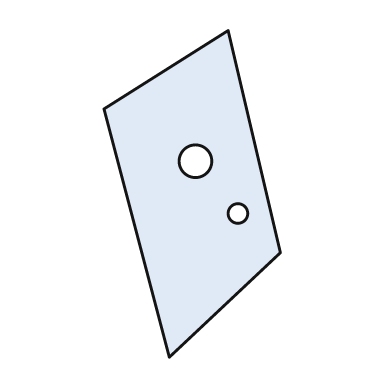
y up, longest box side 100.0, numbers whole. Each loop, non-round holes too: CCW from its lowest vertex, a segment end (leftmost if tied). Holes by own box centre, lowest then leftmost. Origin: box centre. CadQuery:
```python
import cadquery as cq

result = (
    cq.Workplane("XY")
    .moveTo(-7.0, -50.0)
    .lineTo(27.0, -18.0)
    .lineTo(11.0, 50.0)
    .lineTo(-27.0, 26.0)
    .close()
    .moveTo(14.0, -6.0)
    .circle(3.0)
    .moveTo(1.0, 10.0)
    .circle(5.0)
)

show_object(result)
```